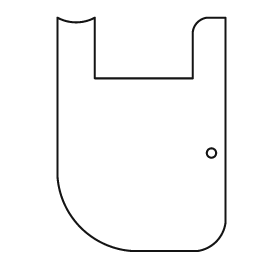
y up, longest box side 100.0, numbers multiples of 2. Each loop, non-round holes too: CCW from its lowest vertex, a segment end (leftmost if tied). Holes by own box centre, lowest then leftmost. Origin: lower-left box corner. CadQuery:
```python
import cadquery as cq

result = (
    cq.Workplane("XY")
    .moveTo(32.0, 0.0)
    .lineTo(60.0, 0.0)
    .threePointArc((68.0, 4.0), (72.0, 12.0))
    .lineTo(72.0, 100.0)
    .lineTo(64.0, 100.0)
    .threePointArc((60.0, 98.0), (58.0, 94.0))
    .lineTo(58.0, 74.0)
    .lineTo(16.0, 74.0)
    .lineTo(16.0, 100.0)
    .threePointArc((8.0, 98.0), (0.0, 100.0))
    .lineTo(0.0, 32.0)
    .threePointArc((10.0, 10.0), (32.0, 0.0))
    .close()
    .moveTo(66.0, 42.0)
    .circle(2.0)
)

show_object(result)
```